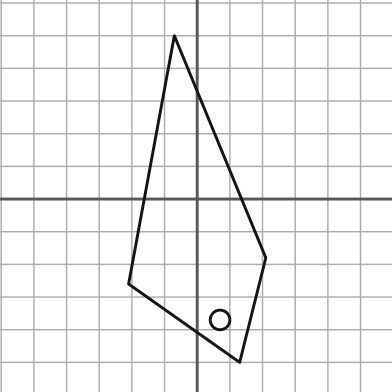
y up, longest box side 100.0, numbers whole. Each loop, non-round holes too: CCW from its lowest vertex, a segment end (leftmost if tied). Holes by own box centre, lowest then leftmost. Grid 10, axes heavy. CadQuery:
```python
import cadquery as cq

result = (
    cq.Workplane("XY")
    .moveTo(13.0, -50.0)
    .lineTo(21.0, -18.0)
    .lineTo(-7.0, 50.0)
    .lineTo(-21.0, -26.0)
    .close()
    .moveTo(7.0, -37.0)
    .circle(3.0)
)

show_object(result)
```